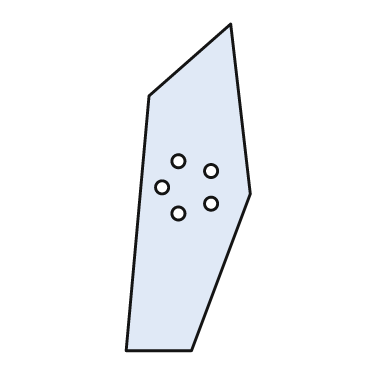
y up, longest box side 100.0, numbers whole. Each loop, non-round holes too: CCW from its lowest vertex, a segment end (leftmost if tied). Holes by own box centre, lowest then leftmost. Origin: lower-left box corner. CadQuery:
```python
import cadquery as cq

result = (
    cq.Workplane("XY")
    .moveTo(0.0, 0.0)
    .lineTo(20.0, 0.0)
    .lineTo(38.0, 48.0)
    .lineTo(32.0, 100.0)
    .lineTo(7.0, 78.0)
    .close()
    .moveTo(16.0, 42.0)
    .circle(2.0)
    .moveTo(26.0, 45.0)
    .circle(2.0)
    .moveTo(11.0, 50.0)
    .circle(2.0)
    .moveTo(26.0, 55.0)
    .circle(2.0)
    .moveTo(16.0, 58.0)
    .circle(2.0)
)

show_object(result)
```